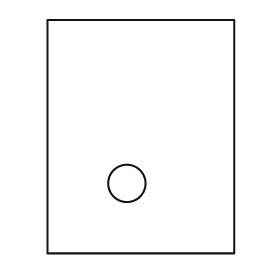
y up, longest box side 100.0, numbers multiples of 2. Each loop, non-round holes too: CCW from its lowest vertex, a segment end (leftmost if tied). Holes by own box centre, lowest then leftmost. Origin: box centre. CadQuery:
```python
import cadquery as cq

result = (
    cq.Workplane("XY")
    .moveTo(-40.0, -50.0)
    .lineTo(40.0, -50.0)
    .lineTo(40.0, 50.0)
    .lineTo(-40.0, 50.0)
    .close()
    .moveTo(-6.0, -20.0)
    .circle(8.0)
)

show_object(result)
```